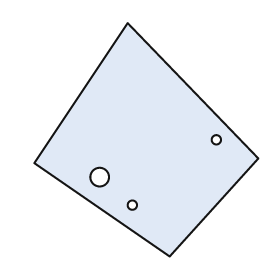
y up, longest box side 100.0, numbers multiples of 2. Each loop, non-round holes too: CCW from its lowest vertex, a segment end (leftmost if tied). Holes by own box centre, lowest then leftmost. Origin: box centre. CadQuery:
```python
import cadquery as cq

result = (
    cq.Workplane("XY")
    .moveTo(10.0, -50.0)
    .lineTo(48.0, -8.0)
    .lineTo(-8.0, 50.0)
    .lineTo(-48.0, -10.0)
    .close()
    .moveTo(-6.0, -28.0)
    .circle(2.0)
    .moveTo(-20.0, -16.0)
    .circle(4.0)
    .moveTo(30.0, 0.0)
    .circle(2.0)
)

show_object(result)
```